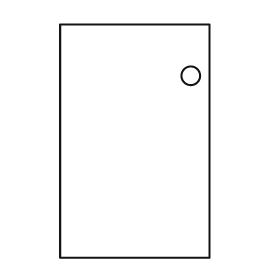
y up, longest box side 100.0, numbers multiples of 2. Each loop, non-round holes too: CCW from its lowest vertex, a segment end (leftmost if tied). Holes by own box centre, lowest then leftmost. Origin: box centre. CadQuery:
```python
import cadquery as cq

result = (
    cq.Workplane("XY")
    .moveTo(-32.0, -50.0)
    .lineTo(32.0, -50.0)
    .lineTo(32.0, 50.0)
    .lineTo(-32.0, 50.0)
    .close()
    .moveTo(24.0, 28.0)
    .circle(4.0)
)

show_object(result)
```